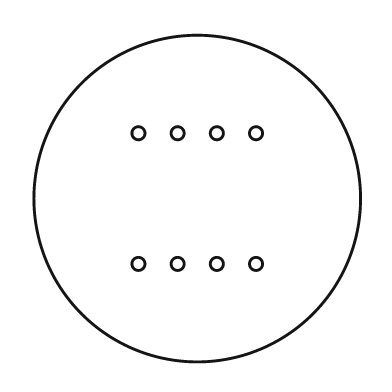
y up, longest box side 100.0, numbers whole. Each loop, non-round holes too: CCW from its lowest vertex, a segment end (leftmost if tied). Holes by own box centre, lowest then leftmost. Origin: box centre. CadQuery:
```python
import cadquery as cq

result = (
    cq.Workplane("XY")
    .moveTo(0.0, 0.0)
    .circle(50.0)
    .moveTo(-18.0, -20.0)
    .circle(2.0)
    .moveTo(-6.0, -20.0)
    .circle(2.0)
    .moveTo(6.0, -20.0)
    .circle(2.0)
    .moveTo(18.0, -20.0)
    .circle(2.0)
    .moveTo(-18.0, 20.0)
    .circle(2.0)
    .moveTo(-6.0, 20.0)
    .circle(2.0)
    .moveTo(6.0, 20.0)
    .circle(2.0)
    .moveTo(18.0, 20.0)
    .circle(2.0)
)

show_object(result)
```